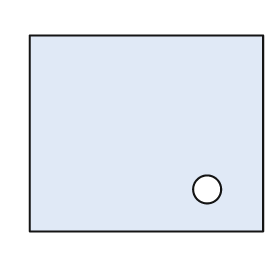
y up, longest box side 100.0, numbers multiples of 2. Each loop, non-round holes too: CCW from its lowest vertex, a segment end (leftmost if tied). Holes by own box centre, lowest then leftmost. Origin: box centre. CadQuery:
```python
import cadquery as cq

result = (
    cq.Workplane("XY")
    .moveTo(-50.0, -42.0)
    .lineTo(50.0, -42.0)
    .lineTo(50.0, 42.0)
    .lineTo(-50.0, 42.0)
    .close()
    .moveTo(26.0, -24.0)
    .circle(6.0)
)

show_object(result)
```